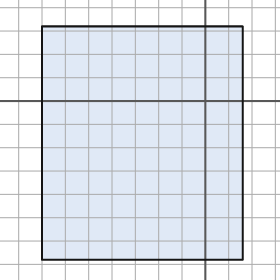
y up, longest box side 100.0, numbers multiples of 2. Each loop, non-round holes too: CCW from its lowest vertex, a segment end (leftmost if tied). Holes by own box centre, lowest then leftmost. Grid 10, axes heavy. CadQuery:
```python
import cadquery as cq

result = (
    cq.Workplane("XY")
    .moveTo(-70.0, -68.0)
    .lineTo(16.0, -68.0)
    .lineTo(16.0, 32.0)
    .lineTo(-70.0, 32.0)
    .close()
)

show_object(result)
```